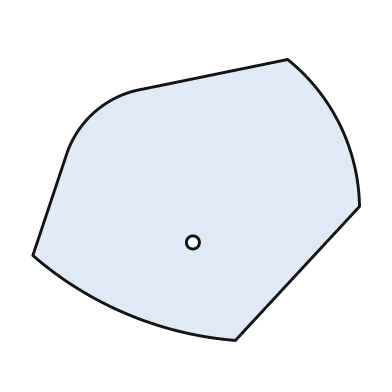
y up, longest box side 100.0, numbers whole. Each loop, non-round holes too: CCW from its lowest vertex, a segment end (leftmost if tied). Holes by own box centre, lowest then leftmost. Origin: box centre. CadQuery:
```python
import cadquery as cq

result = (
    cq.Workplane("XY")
    .moveTo(12.0, -43.0)
    .lineTo(50.0, -2.0)
    .threePointArc((44.0, 23.0), (28.0, 43.0))
    .lineTo(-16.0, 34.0)
    .threePointArc((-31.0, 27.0), (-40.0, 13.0))
    .lineTo(-50.0, -17.0)
    .threePointArc((-21.0, -35.0), (12.0, -43.0))
    .close()
    .moveTo(-1.0, -13.0)
    .circle(2.0)
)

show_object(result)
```